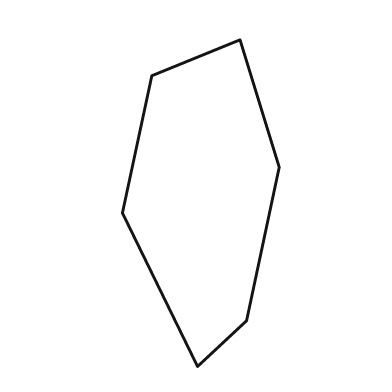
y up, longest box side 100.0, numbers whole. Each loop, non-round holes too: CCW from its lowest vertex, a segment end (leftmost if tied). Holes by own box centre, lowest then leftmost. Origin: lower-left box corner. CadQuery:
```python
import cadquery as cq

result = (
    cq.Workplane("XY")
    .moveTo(23.0, 0.0)
    .lineTo(38.0, 14.0)
    .lineTo(48.0, 61.0)
    .lineTo(36.0, 100.0)
    .lineTo(9.0, 89.0)
    .lineTo(0.0, 47.0)
    .close()
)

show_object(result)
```